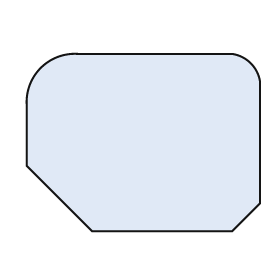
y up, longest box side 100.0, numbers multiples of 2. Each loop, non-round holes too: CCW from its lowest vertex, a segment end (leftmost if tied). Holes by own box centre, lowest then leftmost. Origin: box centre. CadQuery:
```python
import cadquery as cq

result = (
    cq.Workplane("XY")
    .moveTo(-22.0, -38.0)
    .lineTo(38.0, -38.0)
    .lineTo(50.0, -26.0)
    .lineTo(50.0, 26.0)
    .threePointArc((46.0, 34.0), (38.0, 38.0))
    .lineTo(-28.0, 38.0)
    .threePointArc((-44.0, 32.0), (-50.0, 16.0))
    .lineTo(-50.0, -10.0)
    .close()
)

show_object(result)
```